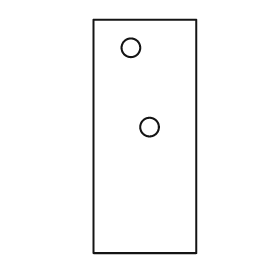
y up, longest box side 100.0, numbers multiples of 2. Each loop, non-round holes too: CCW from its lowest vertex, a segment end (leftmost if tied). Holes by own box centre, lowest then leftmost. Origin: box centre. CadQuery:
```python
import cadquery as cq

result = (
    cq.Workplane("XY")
    .moveTo(-22.0, -50.0)
    .lineTo(22.0, -50.0)
    .lineTo(22.0, 50.0)
    .lineTo(-22.0, 50.0)
    .close()
    .moveTo(2.0, 4.0)
    .circle(4.0)
    .moveTo(-6.0, 38.0)
    .circle(4.0)
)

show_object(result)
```